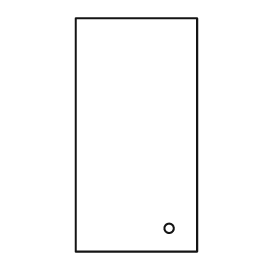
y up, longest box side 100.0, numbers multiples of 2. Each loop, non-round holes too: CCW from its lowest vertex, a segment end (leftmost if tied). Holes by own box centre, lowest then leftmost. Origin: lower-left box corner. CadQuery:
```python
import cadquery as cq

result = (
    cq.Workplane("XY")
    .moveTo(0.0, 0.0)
    .lineTo(52.0, 0.0)
    .lineTo(52.0, 100.0)
    .lineTo(0.0, 100.0)
    .close()
    .moveTo(40.0, 10.0)
    .circle(2.0)
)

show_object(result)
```